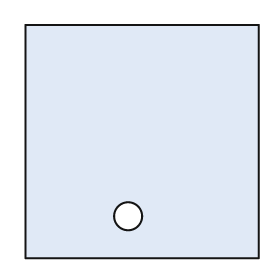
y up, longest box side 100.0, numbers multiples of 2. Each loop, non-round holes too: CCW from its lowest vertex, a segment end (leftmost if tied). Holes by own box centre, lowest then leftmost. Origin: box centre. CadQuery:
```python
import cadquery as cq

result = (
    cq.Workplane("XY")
    .moveTo(-50.0, -50.0)
    .lineTo(50.0, -50.0)
    .lineTo(50.0, 50.0)
    .lineTo(-50.0, 50.0)
    .close()
    .moveTo(-6.0, -32.0)
    .circle(6.0)
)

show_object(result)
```